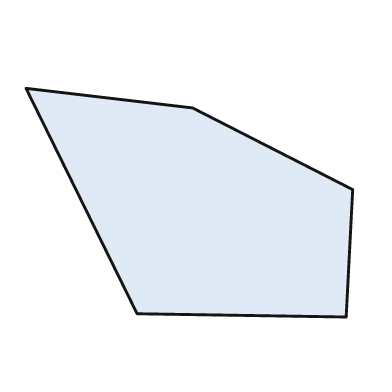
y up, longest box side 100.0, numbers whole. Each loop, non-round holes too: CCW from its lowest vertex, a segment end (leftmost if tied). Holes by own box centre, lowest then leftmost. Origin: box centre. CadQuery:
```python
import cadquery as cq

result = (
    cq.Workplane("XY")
    .moveTo(48.0, -35.0)
    .lineTo(50.0, 4.0)
    .lineTo(1.0, 29.0)
    .lineTo(-50.0, 35.0)
    .lineTo(-16.0, -34.0)
    .close()
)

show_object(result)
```